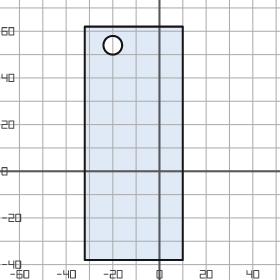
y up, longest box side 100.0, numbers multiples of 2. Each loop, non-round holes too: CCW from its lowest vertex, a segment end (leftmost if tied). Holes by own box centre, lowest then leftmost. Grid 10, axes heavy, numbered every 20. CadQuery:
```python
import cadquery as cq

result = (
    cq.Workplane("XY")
    .moveTo(-32.0, -38.0)
    .lineTo(10.0, -38.0)
    .lineTo(10.0, 62.0)
    .lineTo(-32.0, 62.0)
    .close()
    .moveTo(-20.0, 54.0)
    .circle(4.0)
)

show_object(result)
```